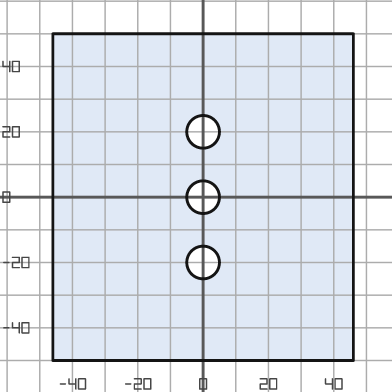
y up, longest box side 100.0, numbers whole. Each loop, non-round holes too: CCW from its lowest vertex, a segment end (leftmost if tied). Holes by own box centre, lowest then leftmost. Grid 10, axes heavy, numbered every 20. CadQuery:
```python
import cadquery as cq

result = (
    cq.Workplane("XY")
    .moveTo(-46.0, -50.0)
    .lineTo(46.0, -50.0)
    .lineTo(46.0, 50.0)
    .lineTo(-46.0, 50.0)
    .close()
    .moveTo(0.0, -20.0)
    .circle(5.0)
    .moveTo(0.0, 0.0)
    .circle(5.0)
    .moveTo(0.0, 20.0)
    .circle(5.0)
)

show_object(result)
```